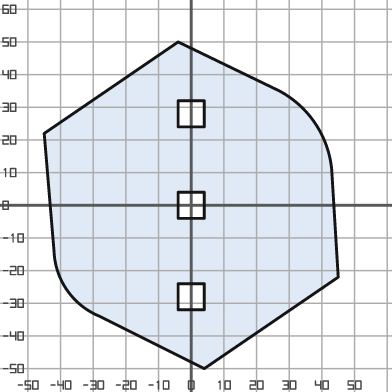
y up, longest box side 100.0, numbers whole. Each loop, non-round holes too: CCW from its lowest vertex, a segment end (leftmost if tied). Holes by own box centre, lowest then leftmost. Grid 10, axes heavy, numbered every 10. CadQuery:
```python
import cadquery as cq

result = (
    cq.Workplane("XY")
    .moveTo(4.0, -50.0)
    .lineTo(45.0, -22.0)
    .lineTo(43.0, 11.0)
    .threePointArc((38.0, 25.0), (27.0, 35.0))
    .lineTo(-4.0, 50.0)
    .lineTo(-45.0, 22.0)
    .lineTo(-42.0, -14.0)
    .threePointArc((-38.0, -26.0), (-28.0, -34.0))
    .close()
    .moveTo(-4.0, -32.0)
    .lineTo(4.0, -32.0)
    .lineTo(4.0, -24.0)
    .lineTo(-4.0, -24.0)
    .close()
    .moveTo(-4.0, -4.0)
    .lineTo(4.0, -4.0)
    .lineTo(4.0, 4.0)
    .lineTo(-4.0, 4.0)
    .close()
    .moveTo(-4.0, 24.0)
    .lineTo(4.0, 24.0)
    .lineTo(4.0, 32.0)
    .lineTo(-4.0, 32.0)
    .close()
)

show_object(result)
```